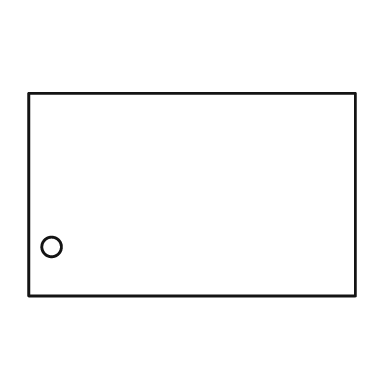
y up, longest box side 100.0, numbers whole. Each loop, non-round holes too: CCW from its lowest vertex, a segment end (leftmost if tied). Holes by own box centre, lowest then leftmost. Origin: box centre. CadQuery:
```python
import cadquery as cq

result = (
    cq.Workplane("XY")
    .moveTo(-50.0, -31.0)
    .lineTo(50.0, -31.0)
    .lineTo(50.0, 31.0)
    .lineTo(-50.0, 31.0)
    .close()
    .moveTo(-43.0, -16.0)
    .circle(3.0)
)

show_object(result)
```